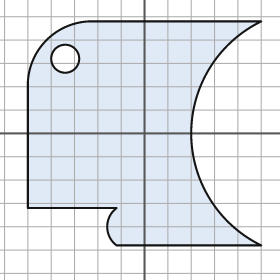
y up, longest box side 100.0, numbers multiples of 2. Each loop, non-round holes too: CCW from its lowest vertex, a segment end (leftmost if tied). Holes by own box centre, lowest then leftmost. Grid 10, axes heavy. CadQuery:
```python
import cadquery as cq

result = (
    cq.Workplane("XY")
    .moveTo(-12.0, -48.0)
    .lineTo(50.0, -48.0)
    .threePointArc((20.0, 0.0), (50.0, 48.0))
    .lineTo(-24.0, 48.0)
    .threePointArc((-42.0, 40.0), (-50.0, 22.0))
    .lineTo(-50.0, -32.0)
    .lineTo(-12.0, -32.0)
    .threePointArc((-16.0, -40.0), (-12.0, -48.0))
    .close()
    .moveTo(-34.0, 32.0)
    .circle(6.0)
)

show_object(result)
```